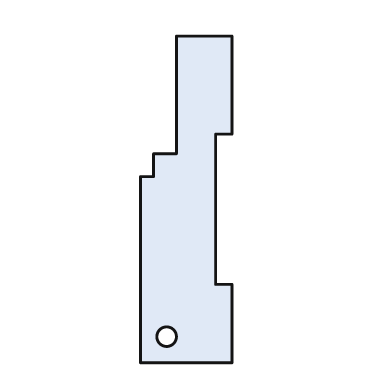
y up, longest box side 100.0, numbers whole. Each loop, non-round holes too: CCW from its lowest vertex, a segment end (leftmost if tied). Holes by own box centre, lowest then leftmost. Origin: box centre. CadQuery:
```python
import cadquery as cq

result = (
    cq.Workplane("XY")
    .moveTo(-14.0, -50.0)
    .lineTo(14.0, -50.0)
    .lineTo(14.0, -26.0)
    .lineTo(9.0, -26.0)
    .lineTo(9.0, 20.0)
    .lineTo(14.0, 20.0)
    .lineTo(14.0, 50.0)
    .lineTo(-3.0, 50.0)
    .lineTo(-3.0, 14.0)
    .lineTo(-10.0, 14.0)
    .lineTo(-10.0, 7.0)
    .lineTo(-14.0, 7.0)
    .close()
    .moveTo(-6.0, -42.0)
    .circle(3.0)
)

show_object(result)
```